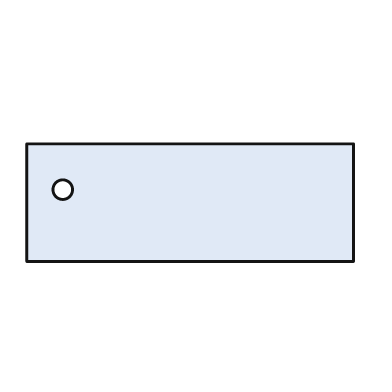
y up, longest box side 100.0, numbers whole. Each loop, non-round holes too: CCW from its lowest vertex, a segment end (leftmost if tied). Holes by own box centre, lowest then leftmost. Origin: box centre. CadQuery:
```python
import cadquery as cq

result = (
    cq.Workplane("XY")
    .moveTo(-50.0, -18.0)
    .lineTo(50.0, -18.0)
    .lineTo(50.0, 18.0)
    .lineTo(-50.0, 18.0)
    .close()
    .moveTo(-39.0, 4.0)
    .circle(3.0)
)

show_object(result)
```